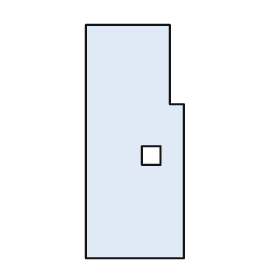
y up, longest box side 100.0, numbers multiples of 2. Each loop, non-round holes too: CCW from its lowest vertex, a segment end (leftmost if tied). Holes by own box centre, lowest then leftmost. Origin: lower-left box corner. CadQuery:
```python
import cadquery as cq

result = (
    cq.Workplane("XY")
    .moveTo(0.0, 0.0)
    .lineTo(42.0, 0.0)
    .lineTo(42.0, 66.0)
    .lineTo(36.0, 66.0)
    .lineTo(36.0, 100.0)
    .lineTo(0.0, 100.0)
    .close()
    .moveTo(24.0, 40.0)
    .lineTo(32.0, 40.0)
    .lineTo(32.0, 48.0)
    .lineTo(24.0, 48.0)
    .close()
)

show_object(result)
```